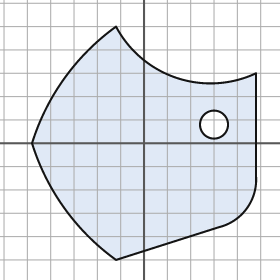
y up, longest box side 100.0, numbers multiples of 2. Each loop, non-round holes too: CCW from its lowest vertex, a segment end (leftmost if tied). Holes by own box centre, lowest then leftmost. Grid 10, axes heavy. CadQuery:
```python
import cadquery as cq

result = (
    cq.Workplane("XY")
    .moveTo(-12.0, -50.0)
    .lineTo(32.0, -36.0)
    .threePointArc((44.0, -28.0), (48.0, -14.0))
    .lineTo(48.0, 30.0)
    .threePointArc((14.0, 28.0), (-12.0, 50.0))
    .threePointArc((-34.0, 28.0), (-48.0, 0.0))
    .threePointArc((-34.0, -28.0), (-12.0, -50.0))
    .close()
    .moveTo(30.0, 8.0)
    .circle(6.0)
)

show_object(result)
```